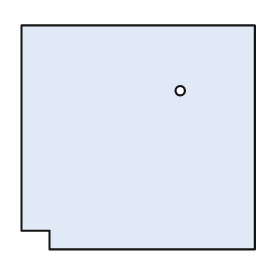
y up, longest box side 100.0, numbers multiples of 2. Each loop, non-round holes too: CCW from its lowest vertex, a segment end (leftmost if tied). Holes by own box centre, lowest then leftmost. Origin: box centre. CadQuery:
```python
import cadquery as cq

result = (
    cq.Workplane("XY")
    .moveTo(-38.0, -48.0)
    .lineTo(50.0, -48.0)
    .lineTo(50.0, 48.0)
    .lineTo(-50.0, 48.0)
    .lineTo(-50.0, -40.0)
    .lineTo(-38.0, -40.0)
    .close()
    .moveTo(18.0, 20.0)
    .circle(2.0)
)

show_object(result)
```